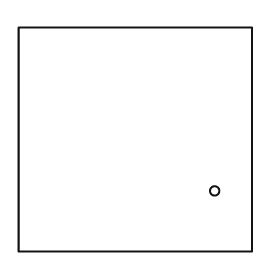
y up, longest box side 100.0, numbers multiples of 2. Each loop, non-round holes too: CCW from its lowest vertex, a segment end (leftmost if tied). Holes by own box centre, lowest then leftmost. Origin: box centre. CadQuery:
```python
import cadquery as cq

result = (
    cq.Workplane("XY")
    .moveTo(-50.0, -48.0)
    .lineTo(50.0, -48.0)
    .lineTo(50.0, 48.0)
    .lineTo(-50.0, 48.0)
    .close()
    .moveTo(34.0, -22.0)
    .circle(2.0)
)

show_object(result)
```